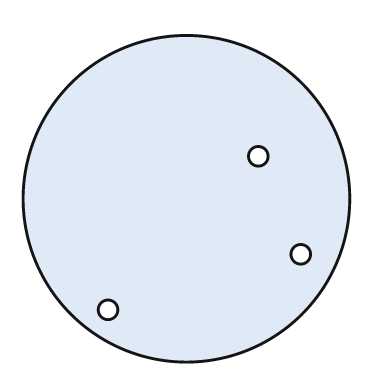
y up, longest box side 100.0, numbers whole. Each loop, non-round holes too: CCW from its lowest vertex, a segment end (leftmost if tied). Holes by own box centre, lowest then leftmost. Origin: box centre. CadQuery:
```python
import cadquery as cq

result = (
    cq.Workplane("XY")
    .moveTo(0.0, 0.0)
    .circle(50.0)
    .moveTo(-24.0, -34.0)
    .circle(3.0)
    .moveTo(35.0, -17.0)
    .circle(3.0)
    .moveTo(22.0, 13.0)
    .circle(3.0)
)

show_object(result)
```